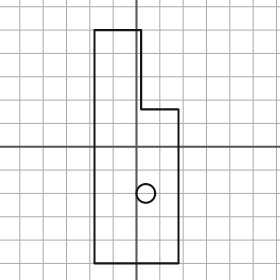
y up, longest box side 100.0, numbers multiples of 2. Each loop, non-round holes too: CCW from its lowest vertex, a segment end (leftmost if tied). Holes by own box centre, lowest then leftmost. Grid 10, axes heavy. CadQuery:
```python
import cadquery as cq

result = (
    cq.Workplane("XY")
    .moveTo(-18.0, -50.0)
    .lineTo(18.0, -50.0)
    .lineTo(18.0, 16.0)
    .lineTo(2.0, 16.0)
    .lineTo(2.0, 50.0)
    .lineTo(-18.0, 50.0)
    .close()
    .moveTo(4.0, -20.0)
    .circle(4.0)
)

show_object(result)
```